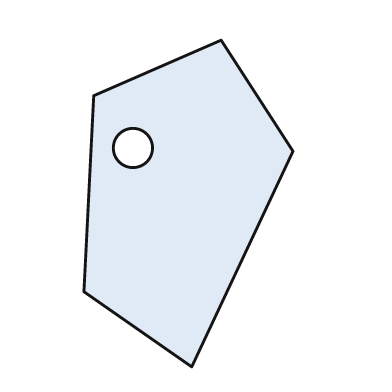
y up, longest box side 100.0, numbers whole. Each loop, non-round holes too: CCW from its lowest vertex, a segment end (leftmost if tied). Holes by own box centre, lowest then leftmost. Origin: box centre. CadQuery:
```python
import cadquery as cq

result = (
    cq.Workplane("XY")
    .moveTo(1.0, -50.0)
    .lineTo(32.0, 16.0)
    .lineTo(10.0, 50.0)
    .lineTo(-29.0, 33.0)
    .lineTo(-32.0, -27.0)
    .close()
    .moveTo(-17.0, 17.0)
    .circle(6.0)
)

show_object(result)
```